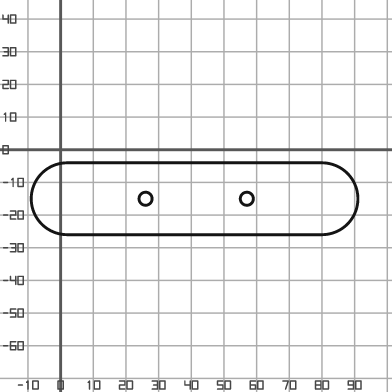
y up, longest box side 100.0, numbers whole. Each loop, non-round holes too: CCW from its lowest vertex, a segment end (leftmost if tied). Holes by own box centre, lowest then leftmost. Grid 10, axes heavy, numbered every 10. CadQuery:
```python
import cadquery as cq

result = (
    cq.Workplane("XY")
    .moveTo(2.0, -26.0)
    .lineTo(80.0, -26.0)
    .threePointArc((91.0, -15.0), (80.0, -4.0))
    .lineTo(2.0, -4.0)
    .threePointArc((-9.0, -15.0), (2.0, -26.0))
    .close()
    .moveTo(26.0, -15.0)
    .circle(2.0)
    .moveTo(57.0, -15.0)
    .circle(2.0)
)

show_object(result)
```